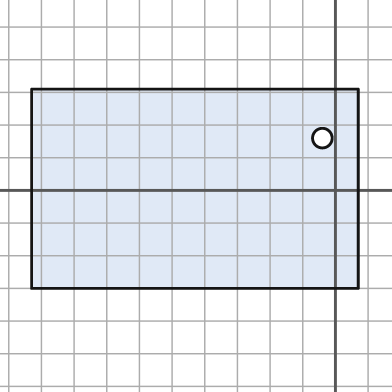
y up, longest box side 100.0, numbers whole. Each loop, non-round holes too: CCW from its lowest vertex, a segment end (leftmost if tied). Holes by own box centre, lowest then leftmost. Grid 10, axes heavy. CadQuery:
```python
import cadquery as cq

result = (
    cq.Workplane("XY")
    .moveTo(-93.0, -30.0)
    .lineTo(7.0, -30.0)
    .lineTo(7.0, 31.0)
    .lineTo(-93.0, 31.0)
    .close()
    .moveTo(-4.0, 16.0)
    .circle(3.0)
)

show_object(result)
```